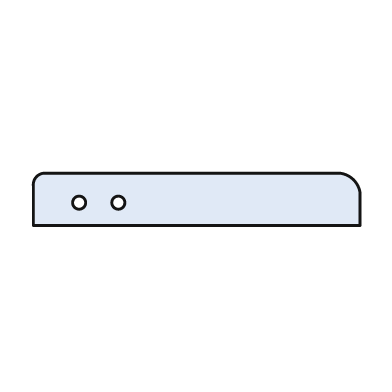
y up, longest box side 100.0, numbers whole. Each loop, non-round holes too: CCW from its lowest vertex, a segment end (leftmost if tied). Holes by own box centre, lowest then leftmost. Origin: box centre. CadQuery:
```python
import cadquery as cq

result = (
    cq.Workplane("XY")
    .moveTo(-50.0, -8.0)
    .lineTo(50.0, -8.0)
    .lineTo(50.0, 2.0)
    .threePointArc((48.0, 6.0), (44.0, 8.0))
    .lineTo(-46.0, 8.0)
    .threePointArc((-49.0, 7.0), (-50.0, 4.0))
    .close()
    .moveTo(-36.0, -1.0)
    .circle(2.0)
    .moveTo(-24.0, -1.0)
    .circle(2.0)
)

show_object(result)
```